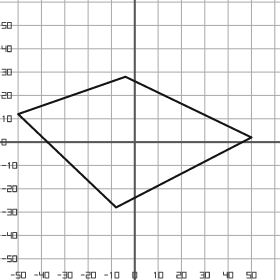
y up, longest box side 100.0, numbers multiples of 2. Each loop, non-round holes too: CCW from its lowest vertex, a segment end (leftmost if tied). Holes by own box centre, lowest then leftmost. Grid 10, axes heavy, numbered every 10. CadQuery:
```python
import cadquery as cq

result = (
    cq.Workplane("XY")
    .moveTo(-8.0, -28.0)
    .lineTo(50.0, 2.0)
    .lineTo(-4.0, 28.0)
    .lineTo(-50.0, 12.0)
    .close()
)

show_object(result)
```